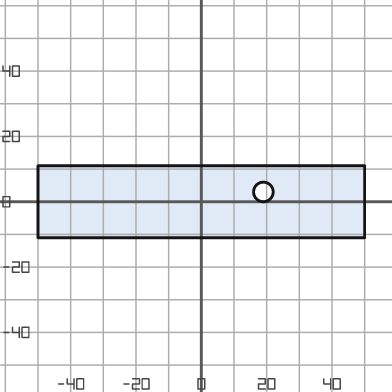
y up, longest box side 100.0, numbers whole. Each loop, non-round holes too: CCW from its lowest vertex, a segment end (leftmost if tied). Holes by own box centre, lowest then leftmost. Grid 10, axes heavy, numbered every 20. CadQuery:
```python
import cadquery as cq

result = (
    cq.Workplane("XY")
    .moveTo(-50.0, -11.0)
    .lineTo(50.0, -11.0)
    .lineTo(50.0, 11.0)
    .lineTo(-50.0, 11.0)
    .close()
    .moveTo(19.0, 3.0)
    .circle(3.0)
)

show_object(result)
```